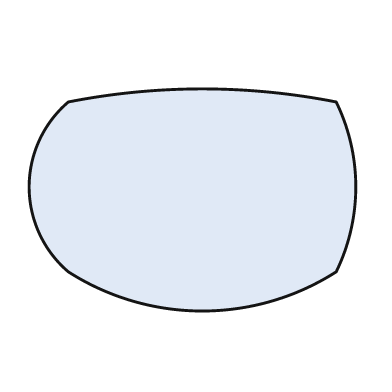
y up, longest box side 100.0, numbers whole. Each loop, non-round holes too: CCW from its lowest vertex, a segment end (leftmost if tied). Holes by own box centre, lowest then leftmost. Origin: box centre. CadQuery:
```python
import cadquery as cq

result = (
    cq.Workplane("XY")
    .moveTo(-38.0, -22.0)
    .threePointArc((3.0, -34.0), (44.0, -22.0))
    .threePointArc((50.0, 4.0), (44.0, 30.0))
    .threePointArc((3.0, 34.0), (-38.0, 30.0))
    .threePointArc((-50.0, 4.0), (-38.0, -22.0))
    .close()
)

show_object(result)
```